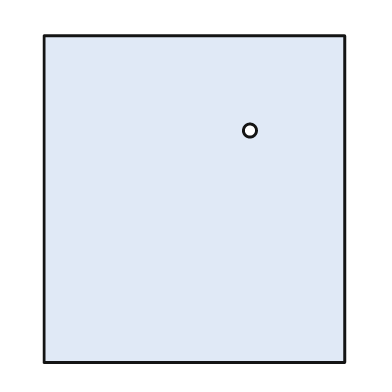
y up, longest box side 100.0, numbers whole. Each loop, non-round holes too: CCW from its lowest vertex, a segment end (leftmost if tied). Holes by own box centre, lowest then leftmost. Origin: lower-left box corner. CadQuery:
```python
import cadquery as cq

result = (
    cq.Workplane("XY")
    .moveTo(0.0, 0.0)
    .lineTo(92.0, 0.0)
    .lineTo(92.0, 100.0)
    .lineTo(0.0, 100.0)
    .close()
    .moveTo(63.0, 71.0)
    .circle(2.0)
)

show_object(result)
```